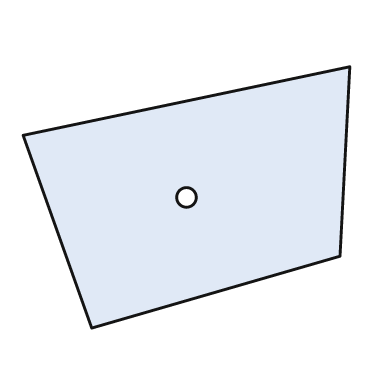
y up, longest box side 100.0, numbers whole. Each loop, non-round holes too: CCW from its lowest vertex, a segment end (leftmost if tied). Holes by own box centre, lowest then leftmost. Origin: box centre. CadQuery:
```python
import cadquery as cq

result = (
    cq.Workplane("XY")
    .moveTo(-29.0, -40.0)
    .lineTo(47.0, -18.0)
    .lineTo(50.0, 40.0)
    .lineTo(-50.0, 19.0)
    .close()
    .moveTo(0.0, 0.0)
    .circle(3.0)
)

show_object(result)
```